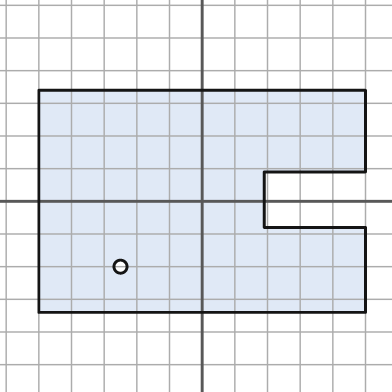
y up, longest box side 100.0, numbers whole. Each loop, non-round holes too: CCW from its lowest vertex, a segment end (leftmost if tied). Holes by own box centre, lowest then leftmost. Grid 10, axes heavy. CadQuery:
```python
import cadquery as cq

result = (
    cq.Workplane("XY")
    .moveTo(-50.0, -34.0)
    .lineTo(50.0, -34.0)
    .lineTo(50.0, -8.0)
    .lineTo(19.0, -8.0)
    .lineTo(19.0, 9.0)
    .lineTo(50.0, 9.0)
    .lineTo(50.0, 34.0)
    .lineTo(-50.0, 34.0)
    .close()
    .moveTo(-25.0, -20.0)
    .circle(2.0)
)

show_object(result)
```